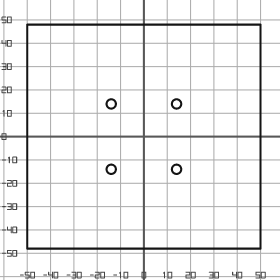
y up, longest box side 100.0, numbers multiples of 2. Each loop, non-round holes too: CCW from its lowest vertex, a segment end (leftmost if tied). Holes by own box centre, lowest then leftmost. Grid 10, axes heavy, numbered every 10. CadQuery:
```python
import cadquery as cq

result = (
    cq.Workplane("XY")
    .moveTo(-50.0, -48.0)
    .lineTo(50.0, -48.0)
    .lineTo(50.0, 48.0)
    .lineTo(-50.0, 48.0)
    .close()
    .moveTo(-14.0, -14.0)
    .circle(2.0)
    .moveTo(14.0, -14.0)
    .circle(2.0)
    .moveTo(-14.0, 14.0)
    .circle(2.0)
    .moveTo(14.0, 14.0)
    .circle(2.0)
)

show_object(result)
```